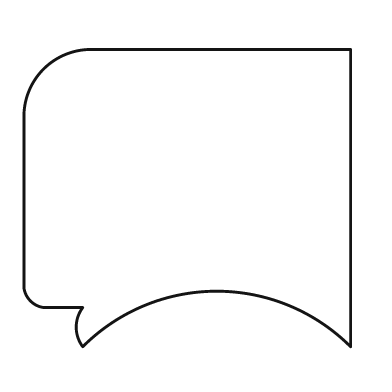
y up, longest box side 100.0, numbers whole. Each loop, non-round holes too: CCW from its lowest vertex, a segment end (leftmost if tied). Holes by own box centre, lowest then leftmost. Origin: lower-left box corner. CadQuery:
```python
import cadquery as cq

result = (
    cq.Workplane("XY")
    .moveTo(18.0, 0.0)
    .threePointArc((59.0, 17.0), (100.0, 0.0))
    .lineTo(100.0, 91.0)
    .lineTo(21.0, 91.0)
    .threePointArc((6.0, 85.0), (0.0, 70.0))
    .lineTo(0.0, 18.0)
    .threePointArc((2.0, 14.0), (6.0, 12.0))
    .lineTo(18.0, 12.0)
    .threePointArc((16.0, 6.0), (18.0, 0.0))
    .close()
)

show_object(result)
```